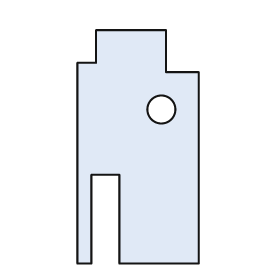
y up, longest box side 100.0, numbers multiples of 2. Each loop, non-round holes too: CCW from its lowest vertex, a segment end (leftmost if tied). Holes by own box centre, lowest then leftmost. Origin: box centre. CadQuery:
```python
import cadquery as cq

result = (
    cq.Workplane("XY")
    .moveTo(-26.0, -50.0)
    .lineTo(-20.0, -50.0)
    .lineTo(-20.0, -12.0)
    .lineTo(-8.0, -12.0)
    .lineTo(-8.0, -50.0)
    .lineTo(26.0, -50.0)
    .lineTo(26.0, 32.0)
    .lineTo(12.0, 32.0)
    .lineTo(12.0, 50.0)
    .lineTo(-18.0, 50.0)
    .lineTo(-18.0, 36.0)
    .lineTo(-26.0, 36.0)
    .close()
    .moveTo(10.0, 16.0)
    .circle(6.0)
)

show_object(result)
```